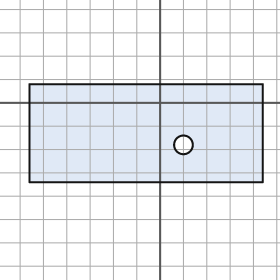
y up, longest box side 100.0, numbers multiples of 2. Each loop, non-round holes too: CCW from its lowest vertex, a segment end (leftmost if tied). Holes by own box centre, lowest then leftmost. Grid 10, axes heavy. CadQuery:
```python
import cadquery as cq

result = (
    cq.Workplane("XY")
    .moveTo(-56.0, -34.0)
    .lineTo(44.0, -34.0)
    .lineTo(44.0, 8.0)
    .lineTo(-56.0, 8.0)
    .close()
    .moveTo(10.0, -18.0)
    .circle(4.0)
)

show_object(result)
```